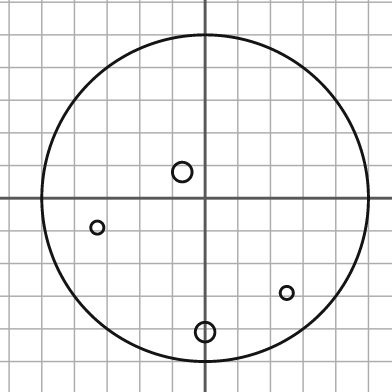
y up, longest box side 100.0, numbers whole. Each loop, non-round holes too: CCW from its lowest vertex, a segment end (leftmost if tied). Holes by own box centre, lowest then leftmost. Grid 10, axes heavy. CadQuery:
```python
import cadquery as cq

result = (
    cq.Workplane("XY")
    .moveTo(0.0, 0.0)
    .circle(50.0)
    .moveTo(0.0, -41.0)
    .circle(3.0)
    .moveTo(25.0, -29.0)
    .circle(2.0)
    .moveTo(-33.0, -9.0)
    .circle(2.0)
    .moveTo(-7.0, 8.0)
    .circle(3.0)
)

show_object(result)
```